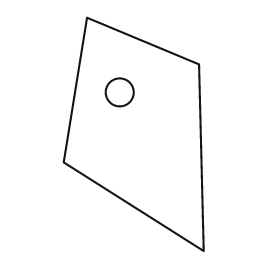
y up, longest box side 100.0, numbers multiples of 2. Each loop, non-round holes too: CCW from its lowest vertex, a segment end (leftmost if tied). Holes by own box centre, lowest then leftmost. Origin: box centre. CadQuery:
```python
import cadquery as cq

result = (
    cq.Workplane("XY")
    .moveTo(30.0, -50.0)
    .lineTo(28.0, 30.0)
    .lineTo(-20.0, 50.0)
    .lineTo(-30.0, -12.0)
    .close()
    .moveTo(-6.0, 18.0)
    .circle(6.0)
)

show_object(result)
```